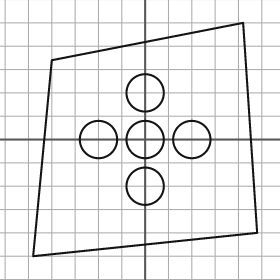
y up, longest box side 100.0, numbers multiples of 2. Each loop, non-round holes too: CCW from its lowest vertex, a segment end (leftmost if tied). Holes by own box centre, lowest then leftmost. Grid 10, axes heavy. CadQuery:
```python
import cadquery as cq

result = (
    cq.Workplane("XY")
    .moveTo(-48.0, -50.0)
    .lineTo(48.0, -40.0)
    .lineTo(42.0, 50.0)
    .lineTo(-40.0, 34.0)
    .close()
    .moveTo(0.0, -20.0)
    .circle(8.0)
    .moveTo(-20.0, 0.0)
    .circle(8.0)
    .moveTo(0.0, 0.0)
    .circle(8.0)
    .moveTo(20.0, 0.0)
    .circle(8.0)
    .moveTo(0.0, 20.0)
    .circle(8.0)
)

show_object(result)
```